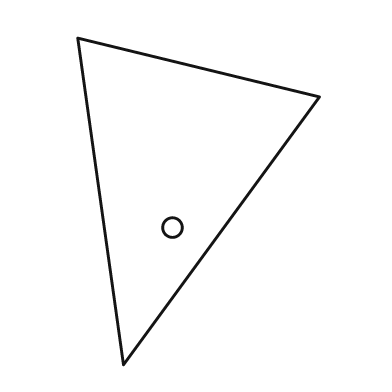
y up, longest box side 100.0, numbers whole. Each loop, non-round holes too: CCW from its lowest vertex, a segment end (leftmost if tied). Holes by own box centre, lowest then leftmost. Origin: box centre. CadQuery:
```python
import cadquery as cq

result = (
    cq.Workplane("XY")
    .moveTo(-23.0, -50.0)
    .lineTo(37.0, 32.0)
    .lineTo(-37.0, 50.0)
    .close()
    .moveTo(-8.0, -8.0)
    .circle(3.0)
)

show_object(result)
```